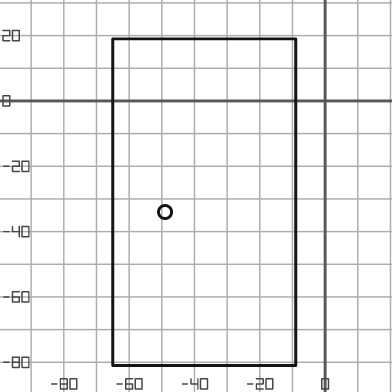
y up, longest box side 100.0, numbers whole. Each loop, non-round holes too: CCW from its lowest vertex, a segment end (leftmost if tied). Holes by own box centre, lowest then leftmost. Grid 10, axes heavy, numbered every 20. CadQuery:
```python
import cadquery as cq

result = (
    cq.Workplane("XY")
    .moveTo(-65.0, -81.0)
    .lineTo(-9.0, -81.0)
    .lineTo(-9.0, 19.0)
    .lineTo(-65.0, 19.0)
    .close()
    .moveTo(-49.0, -34.0)
    .circle(2.0)
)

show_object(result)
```